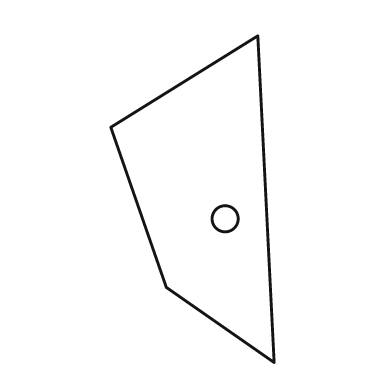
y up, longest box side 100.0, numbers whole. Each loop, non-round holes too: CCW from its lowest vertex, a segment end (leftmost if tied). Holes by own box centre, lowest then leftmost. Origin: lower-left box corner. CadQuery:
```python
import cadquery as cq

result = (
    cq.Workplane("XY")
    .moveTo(50.0, 0.0)
    .lineTo(45.0, 100.0)
    .lineTo(0.0, 72.0)
    .lineTo(17.0, 23.0)
    .close()
    .moveTo(35.0, 44.0)
    .circle(4.0)
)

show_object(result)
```